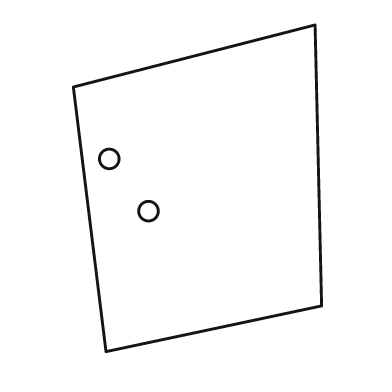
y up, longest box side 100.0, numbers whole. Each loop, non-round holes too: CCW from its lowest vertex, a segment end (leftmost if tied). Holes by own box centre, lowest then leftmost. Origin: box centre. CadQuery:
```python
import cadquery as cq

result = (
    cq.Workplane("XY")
    .moveTo(-28.0, -50.0)
    .lineTo(38.0, -36.0)
    .lineTo(36.0, 50.0)
    .lineTo(-38.0, 31.0)
    .close()
    .moveTo(-15.0, -7.0)
    .circle(3.0)
    .moveTo(-27.0, 9.0)
    .circle(3.0)
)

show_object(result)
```